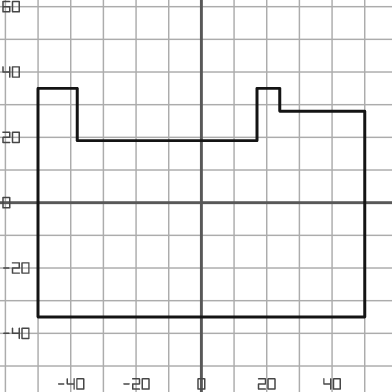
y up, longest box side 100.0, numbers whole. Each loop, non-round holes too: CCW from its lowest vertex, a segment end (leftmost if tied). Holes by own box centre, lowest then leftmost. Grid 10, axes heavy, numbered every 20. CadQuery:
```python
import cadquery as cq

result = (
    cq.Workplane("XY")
    .moveTo(-50.0, -35.0)
    .lineTo(50.0, -35.0)
    .lineTo(50.0, 28.0)
    .lineTo(24.0, 28.0)
    .lineTo(24.0, 35.0)
    .lineTo(17.0, 35.0)
    .lineTo(17.0, 19.0)
    .lineTo(-38.0, 19.0)
    .lineTo(-38.0, 35.0)
    .lineTo(-50.0, 35.0)
    .close()
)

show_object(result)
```